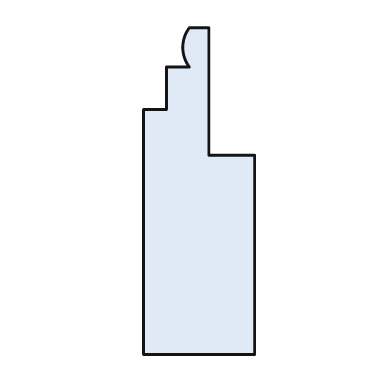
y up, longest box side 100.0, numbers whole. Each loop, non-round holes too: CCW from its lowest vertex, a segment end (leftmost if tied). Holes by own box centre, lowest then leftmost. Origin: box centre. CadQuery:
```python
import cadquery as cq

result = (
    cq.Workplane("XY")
    .moveTo(-17.0, -50.0)
    .lineTo(17.0, -50.0)
    .lineTo(17.0, 11.0)
    .lineTo(3.0, 11.0)
    .lineTo(3.0, 50.0)
    .lineTo(-3.0, 50.0)
    .threePointArc((-5.0, 44.0), (-3.0, 38.0))
    .lineTo(-10.0, 38.0)
    .lineTo(-10.0, 25.0)
    .lineTo(-17.0, 25.0)
    .close()
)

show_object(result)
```